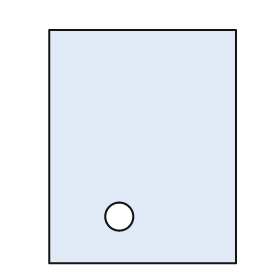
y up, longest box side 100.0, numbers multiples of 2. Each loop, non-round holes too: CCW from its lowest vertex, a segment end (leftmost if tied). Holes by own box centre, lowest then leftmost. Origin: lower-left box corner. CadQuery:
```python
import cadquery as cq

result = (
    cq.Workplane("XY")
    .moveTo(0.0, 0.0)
    .lineTo(80.0, 0.0)
    .lineTo(80.0, 100.0)
    .lineTo(0.0, 100.0)
    .close()
    .moveTo(30.0, 20.0)
    .circle(6.0)
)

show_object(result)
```